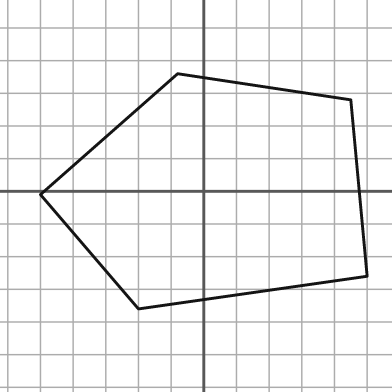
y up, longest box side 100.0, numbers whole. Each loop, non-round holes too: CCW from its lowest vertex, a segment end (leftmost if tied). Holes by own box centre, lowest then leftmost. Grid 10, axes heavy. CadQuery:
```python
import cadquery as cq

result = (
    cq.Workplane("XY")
    .moveTo(-20.0, -36.0)
    .lineTo(50.0, -26.0)
    .lineTo(45.0, 28.0)
    .lineTo(-8.0, 36.0)
    .lineTo(-50.0, -1.0)
    .close()
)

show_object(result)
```